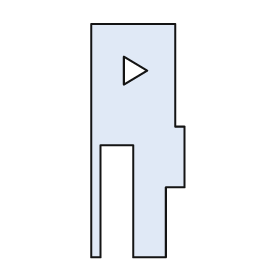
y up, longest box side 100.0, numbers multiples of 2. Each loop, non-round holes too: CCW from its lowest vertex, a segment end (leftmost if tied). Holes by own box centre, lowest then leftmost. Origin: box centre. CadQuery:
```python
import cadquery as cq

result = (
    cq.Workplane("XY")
    .moveTo(-20.0, -50.0)
    .lineTo(-16.0, -50.0)
    .lineTo(-16.0, -2.0)
    .lineTo(-2.0, -2.0)
    .lineTo(-2.0, -50.0)
    .lineTo(12.0, -50.0)
    .lineTo(12.0, -20.0)
    .lineTo(20.0, -20.0)
    .lineTo(20.0, 6.0)
    .lineTo(16.0, 6.0)
    .lineTo(16.0, 50.0)
    .lineTo(-20.0, 50.0)
    .close()
    .moveTo(-6.0, 24.0)
    .lineTo(4.0, 30.0)
    .lineTo(-6.0, 36.0)
    .close()
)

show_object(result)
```